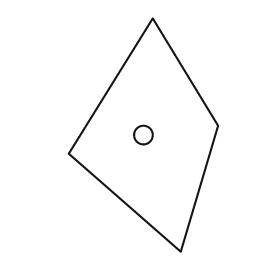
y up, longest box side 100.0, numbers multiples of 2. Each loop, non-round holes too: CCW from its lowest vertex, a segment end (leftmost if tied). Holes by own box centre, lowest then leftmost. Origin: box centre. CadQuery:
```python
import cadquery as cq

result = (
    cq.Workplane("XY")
    .moveTo(16.0, -50.0)
    .lineTo(32.0, 4.0)
    .lineTo(4.0, 50.0)
    .lineTo(-32.0, -8.0)
    .close()
    .moveTo(0.0, 0.0)
    .circle(4.0)
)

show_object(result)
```